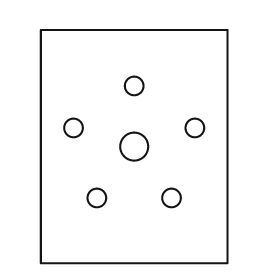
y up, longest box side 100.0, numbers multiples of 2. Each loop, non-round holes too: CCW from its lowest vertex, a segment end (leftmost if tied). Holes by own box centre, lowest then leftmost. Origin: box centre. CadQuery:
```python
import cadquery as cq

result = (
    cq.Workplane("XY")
    .moveTo(-40.0, -50.0)
    .lineTo(40.0, -50.0)
    .lineTo(40.0, 50.0)
    .lineTo(-40.0, 50.0)
    .close()
    .moveTo(-16.0, -22.0)
    .circle(4.0)
    .moveTo(16.0, -22.0)
    .circle(4.0)
    .moveTo(0.0, 0.0)
    .circle(6.0)
    .moveTo(-26.0, 8.0)
    .circle(4.0)
    .moveTo(26.0, 8.0)
    .circle(4.0)
    .moveTo(0.0, 26.0)
    .circle(4.0)
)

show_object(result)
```